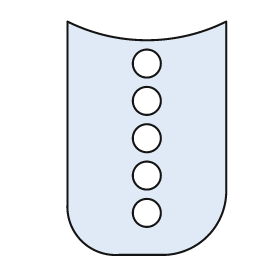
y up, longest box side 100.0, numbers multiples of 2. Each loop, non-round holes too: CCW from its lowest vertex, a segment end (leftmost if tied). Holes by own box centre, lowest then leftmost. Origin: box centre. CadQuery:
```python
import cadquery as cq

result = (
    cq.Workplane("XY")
    .moveTo(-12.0, -50.0)
    .lineTo(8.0, -50.0)
    .threePointArc((26.0, -42.0), (34.0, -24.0))
    .lineTo(34.0, 50.0)
    .threePointArc((0.0, 42.0), (-34.0, 50.0))
    .lineTo(-34.0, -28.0)
    .threePointArc((-28.0, -44.0), (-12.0, -50.0))
    .close()
    .moveTo(0.0, -32.0)
    .circle(6.0)
    .moveTo(0.0, -16.0)
    .circle(6.0)
    .moveTo(0.0, 0.0)
    .circle(6.0)
    .moveTo(0.0, 16.0)
    .circle(6.0)
    .moveTo(0.0, 32.0)
    .circle(6.0)
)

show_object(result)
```